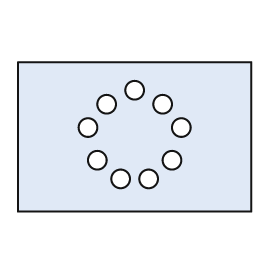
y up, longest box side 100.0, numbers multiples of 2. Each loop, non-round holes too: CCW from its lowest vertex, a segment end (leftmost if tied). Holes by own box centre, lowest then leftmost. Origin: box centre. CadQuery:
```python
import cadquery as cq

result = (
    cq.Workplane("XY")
    .moveTo(-50.0, -32.0)
    .lineTo(50.0, -32.0)
    .lineTo(50.0, 32.0)
    .lineTo(-50.0, 32.0)
    .close()
    .moveTo(-6.0, -18.0)
    .circle(4.0)
    .moveTo(6.0, -18.0)
    .circle(4.0)
    .moveTo(-16.0, -10.0)
    .circle(4.0)
    .moveTo(16.0, -10.0)
    .circle(4.0)
    .moveTo(-20.0, 4.0)
    .circle(4.0)
    .moveTo(20.0, 4.0)
    .circle(4.0)
    .moveTo(-12.0, 14.0)
    .circle(4.0)
    .moveTo(12.0, 14.0)
    .circle(4.0)
    .moveTo(0.0, 20.0)
    .circle(4.0)
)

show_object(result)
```